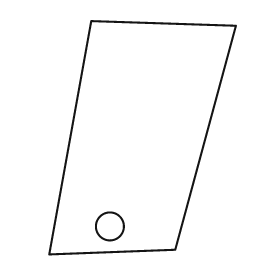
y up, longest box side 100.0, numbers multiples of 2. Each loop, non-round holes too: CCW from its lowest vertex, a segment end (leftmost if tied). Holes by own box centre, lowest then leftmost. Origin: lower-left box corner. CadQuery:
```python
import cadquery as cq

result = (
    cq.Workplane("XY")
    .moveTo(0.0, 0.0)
    .lineTo(54.0, 2.0)
    .lineTo(80.0, 98.0)
    .lineTo(18.0, 100.0)
    .close()
    .moveTo(26.0, 12.0)
    .circle(6.0)
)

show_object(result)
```